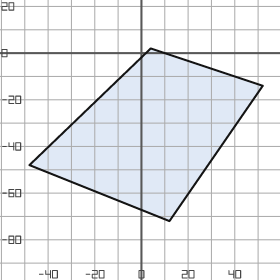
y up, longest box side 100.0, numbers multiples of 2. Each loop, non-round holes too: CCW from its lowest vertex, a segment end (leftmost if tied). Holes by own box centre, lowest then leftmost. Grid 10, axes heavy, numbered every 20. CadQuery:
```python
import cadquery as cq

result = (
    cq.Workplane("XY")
    .moveTo(12.0, -72.0)
    .lineTo(52.0, -14.0)
    .lineTo(4.0, 2.0)
    .lineTo(-48.0, -48.0)
    .close()
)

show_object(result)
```